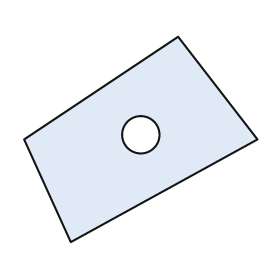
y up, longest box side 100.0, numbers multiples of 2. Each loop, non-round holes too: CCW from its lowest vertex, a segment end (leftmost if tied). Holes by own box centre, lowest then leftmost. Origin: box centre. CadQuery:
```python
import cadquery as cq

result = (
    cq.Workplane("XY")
    .moveTo(-30.0, -44.0)
    .lineTo(50.0, 0.0)
    .lineTo(16.0, 44.0)
    .lineTo(-50.0, 0.0)
    .close()
    .moveTo(0.0, 2.0)
    .circle(8.0)
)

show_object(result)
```